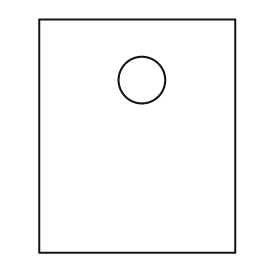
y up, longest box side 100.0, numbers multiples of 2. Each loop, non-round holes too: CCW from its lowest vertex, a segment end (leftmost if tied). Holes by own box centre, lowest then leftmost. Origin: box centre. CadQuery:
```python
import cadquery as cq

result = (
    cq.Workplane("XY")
    .moveTo(-42.0, -50.0)
    .lineTo(42.0, -50.0)
    .lineTo(42.0, 50.0)
    .lineTo(-42.0, 50.0)
    .close()
    .moveTo(2.0, 24.0)
    .circle(10.0)
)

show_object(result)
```